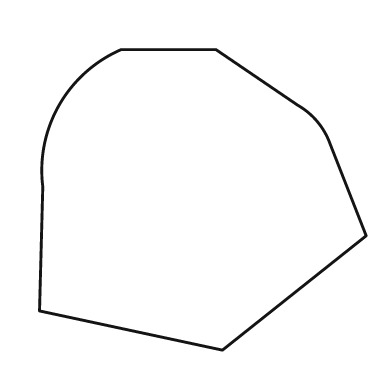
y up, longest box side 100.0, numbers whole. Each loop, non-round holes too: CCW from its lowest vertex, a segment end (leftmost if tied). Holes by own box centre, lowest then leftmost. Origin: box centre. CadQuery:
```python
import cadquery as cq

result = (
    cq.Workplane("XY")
    .moveTo(6.0, -46.0)
    .lineTo(50.0, -11.0)
    .lineTo(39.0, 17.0)
    .threePointArc((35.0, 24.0), (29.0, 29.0))
    .lineTo(4.0, 46.0)
    .lineTo(-25.0, 46.0)
    .threePointArc((-44.0, 29.0), (-49.0, 4.0))
    .lineTo(-50.0, -34.0)
    .close()
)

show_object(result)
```